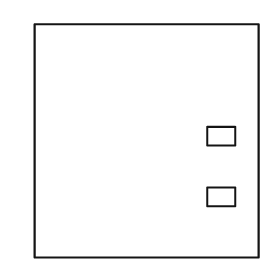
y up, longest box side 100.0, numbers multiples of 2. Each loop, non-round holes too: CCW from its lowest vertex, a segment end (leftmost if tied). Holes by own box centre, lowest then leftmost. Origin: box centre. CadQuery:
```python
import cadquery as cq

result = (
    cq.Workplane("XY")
    .moveTo(-48.0, -50.0)
    .lineTo(48.0, -50.0)
    .lineTo(48.0, 50.0)
    .lineTo(-48.0, 50.0)
    .close()
    .moveTo(26.0, -28.0)
    .lineTo(38.0, -28.0)
    .lineTo(38.0, -20.0)
    .lineTo(26.0, -20.0)
    .close()
    .moveTo(26.0, -2.0)
    .lineTo(38.0, -2.0)
    .lineTo(38.0, 6.0)
    .lineTo(26.0, 6.0)
    .close()
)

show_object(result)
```